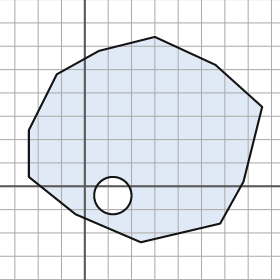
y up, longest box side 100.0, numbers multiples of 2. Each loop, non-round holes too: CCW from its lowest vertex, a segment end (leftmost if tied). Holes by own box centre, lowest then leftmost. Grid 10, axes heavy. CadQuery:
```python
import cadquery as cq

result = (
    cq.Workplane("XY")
    .moveTo(24.0, -24.0)
    .lineTo(58.0, -16.0)
    .lineTo(68.0, 2.0)
    .lineTo(76.0, 34.0)
    .lineTo(56.0, 52.0)
    .lineTo(30.0, 64.0)
    .lineTo(6.0, 58.0)
    .lineTo(-12.0, 48.0)
    .lineTo(-24.0, 24.0)
    .lineTo(-24.0, 4.0)
    .lineTo(-4.0, -12.0)
    .close()
    .moveTo(12.0, -4.0)
    .circle(8.0)
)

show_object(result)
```